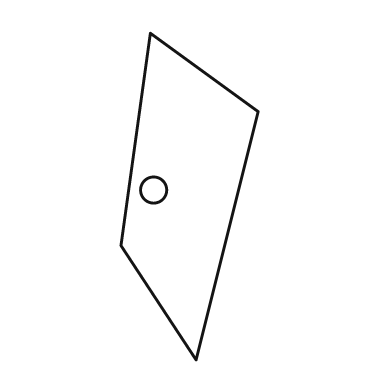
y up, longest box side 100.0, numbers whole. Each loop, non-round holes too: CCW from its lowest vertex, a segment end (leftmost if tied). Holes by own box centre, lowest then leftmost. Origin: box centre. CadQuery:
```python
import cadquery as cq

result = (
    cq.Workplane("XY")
    .moveTo(2.0, -50.0)
    .lineTo(21.0, 26.0)
    .lineTo(-12.0, 50.0)
    .lineTo(-21.0, -15.0)
    .close()
    .moveTo(-11.0, 2.0)
    .circle(4.0)
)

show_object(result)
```